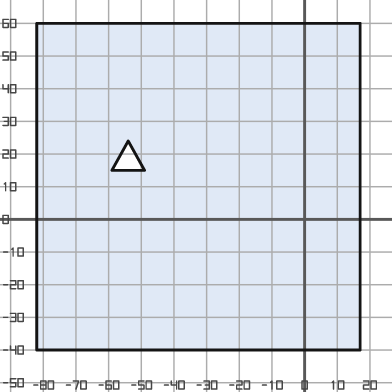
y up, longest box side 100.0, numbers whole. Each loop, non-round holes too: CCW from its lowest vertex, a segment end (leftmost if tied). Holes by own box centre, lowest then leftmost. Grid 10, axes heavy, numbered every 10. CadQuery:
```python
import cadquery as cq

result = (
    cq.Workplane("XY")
    .moveTo(-82.0, -40.0)
    .lineTo(17.0, -40.0)
    .lineTo(17.0, 60.0)
    .lineTo(-82.0, 60.0)
    .close()
    .moveTo(-59.0, 15.0)
    .lineTo(-49.0, 15.0)
    .lineTo(-54.0, 24.0)
    .close()
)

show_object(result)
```